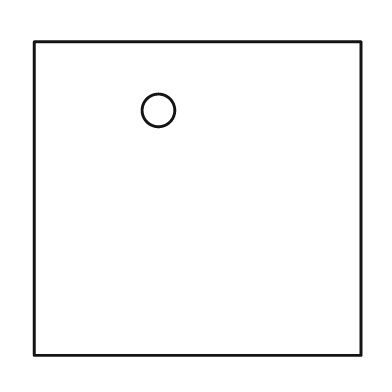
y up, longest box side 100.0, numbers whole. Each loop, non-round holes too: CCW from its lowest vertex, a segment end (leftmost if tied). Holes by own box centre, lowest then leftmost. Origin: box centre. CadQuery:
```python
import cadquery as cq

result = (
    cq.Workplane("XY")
    .moveTo(-50.0, -48.0)
    .lineTo(50.0, -48.0)
    .lineTo(50.0, 48.0)
    .lineTo(-50.0, 48.0)
    .close()
    .moveTo(-12.0, 27.0)
    .circle(5.0)
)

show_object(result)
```